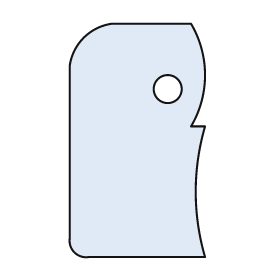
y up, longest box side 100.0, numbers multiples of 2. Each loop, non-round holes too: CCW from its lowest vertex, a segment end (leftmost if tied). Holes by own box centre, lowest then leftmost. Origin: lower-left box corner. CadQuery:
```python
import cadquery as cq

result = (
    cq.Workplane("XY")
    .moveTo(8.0, 0.0)
    .lineTo(58.0, 0.0)
    .threePointArc((54.0, 28.0), (58.0, 56.0))
    .lineTo(52.0, 56.0)
    .threePointArc((58.0, 78.0), (52.0, 100.0))
    .lineTo(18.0, 100.0)
    .threePointArc((6.0, 94.0), (0.0, 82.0))
    .lineTo(0.0, 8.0)
    .threePointArc((2.0, 2.0), (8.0, 0.0))
    .close()
    .moveTo(42.0, 72.0)
    .circle(6.0)
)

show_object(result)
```